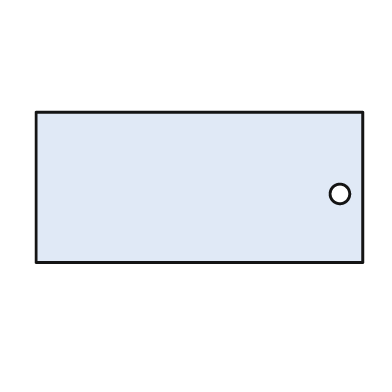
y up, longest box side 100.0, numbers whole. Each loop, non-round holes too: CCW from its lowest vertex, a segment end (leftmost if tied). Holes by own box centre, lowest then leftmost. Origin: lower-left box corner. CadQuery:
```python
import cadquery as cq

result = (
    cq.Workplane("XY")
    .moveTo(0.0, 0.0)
    .lineTo(100.0, 0.0)
    .lineTo(100.0, 46.0)
    .lineTo(0.0, 46.0)
    .close()
    .moveTo(93.0, 21.0)
    .circle(3.0)
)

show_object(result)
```